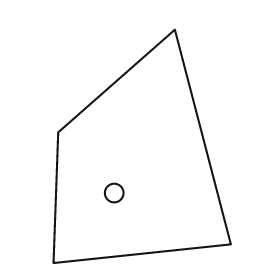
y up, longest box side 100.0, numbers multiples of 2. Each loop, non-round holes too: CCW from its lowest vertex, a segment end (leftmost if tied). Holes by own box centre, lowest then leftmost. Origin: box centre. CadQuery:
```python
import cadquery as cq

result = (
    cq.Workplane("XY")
    .moveTo(-38.0, -50.0)
    .lineTo(38.0, -42.0)
    .lineTo(14.0, 50.0)
    .lineTo(-36.0, 6.0)
    .close()
    .moveTo(-12.0, -20.0)
    .circle(4.0)
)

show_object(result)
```